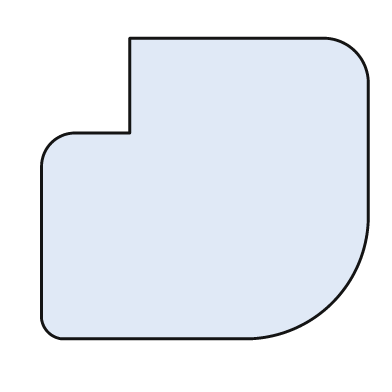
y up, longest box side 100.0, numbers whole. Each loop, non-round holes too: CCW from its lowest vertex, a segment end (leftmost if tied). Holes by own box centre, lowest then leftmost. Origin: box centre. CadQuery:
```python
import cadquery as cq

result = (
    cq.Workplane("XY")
    .moveTo(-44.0, -46.0)
    .lineTo(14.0, -46.0)
    .threePointArc((39.0, -35.0), (50.0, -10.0))
    .lineTo(50.0, 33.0)
    .threePointArc((46.0, 42.0), (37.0, 46.0))
    .lineTo(-23.0, 46.0)
    .lineTo(-23.0, 17.0)
    .lineTo(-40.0, 17.0)
    .threePointArc((-47.0, 14.0), (-50.0, 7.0))
    .lineTo(-50.0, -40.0)
    .threePointArc((-48.0, -44.0), (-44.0, -46.0))
    .close()
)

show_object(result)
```